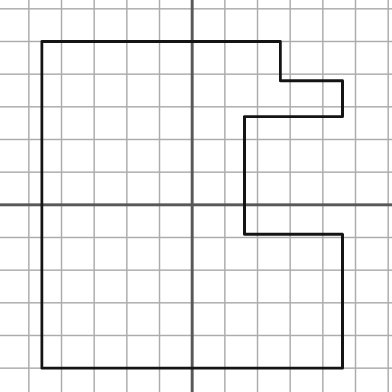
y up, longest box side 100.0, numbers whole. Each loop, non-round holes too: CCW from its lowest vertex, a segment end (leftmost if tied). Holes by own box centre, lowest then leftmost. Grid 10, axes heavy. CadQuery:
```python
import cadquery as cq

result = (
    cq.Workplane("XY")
    .moveTo(-46.0, -50.0)
    .lineTo(46.0, -50.0)
    .lineTo(46.0, -9.0)
    .lineTo(16.0, -9.0)
    .lineTo(16.0, 27.0)
    .lineTo(46.0, 27.0)
    .lineTo(46.0, 38.0)
    .lineTo(27.0, 38.0)
    .lineTo(27.0, 50.0)
    .lineTo(-46.0, 50.0)
    .close()
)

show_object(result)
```